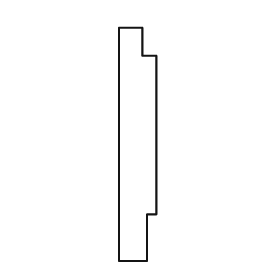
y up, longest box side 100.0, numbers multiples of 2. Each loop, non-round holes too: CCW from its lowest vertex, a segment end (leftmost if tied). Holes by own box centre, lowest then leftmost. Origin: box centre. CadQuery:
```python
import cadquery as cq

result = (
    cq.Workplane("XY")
    .moveTo(-8.0, -50.0)
    .lineTo(4.0, -50.0)
    .lineTo(4.0, -30.0)
    .lineTo(8.0, -30.0)
    .lineTo(8.0, 38.0)
    .lineTo(2.0, 38.0)
    .lineTo(2.0, 50.0)
    .lineTo(-8.0, 50.0)
    .close()
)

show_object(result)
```